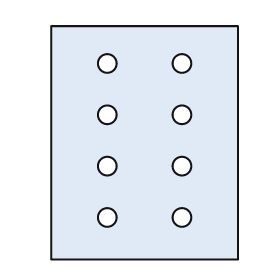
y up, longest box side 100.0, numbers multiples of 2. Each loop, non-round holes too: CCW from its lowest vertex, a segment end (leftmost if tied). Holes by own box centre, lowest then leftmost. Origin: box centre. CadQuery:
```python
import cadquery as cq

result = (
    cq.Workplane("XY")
    .moveTo(-40.0, -50.0)
    .lineTo(40.0, -50.0)
    .lineTo(40.0, 50.0)
    .lineTo(-40.0, 50.0)
    .close()
    .moveTo(-16.0, -32.0)
    .circle(4.0)
    .moveTo(16.0, -32.0)
    .circle(4.0)
    .moveTo(-16.0, -10.0)
    .circle(4.0)
    .moveTo(16.0, -10.0)
    .circle(4.0)
    .moveTo(-16.0, 12.0)
    .circle(4.0)
    .moveTo(16.0, 12.0)
    .circle(4.0)
    .moveTo(-16.0, 34.0)
    .circle(4.0)
    .moveTo(16.0, 34.0)
    .circle(4.0)
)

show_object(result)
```